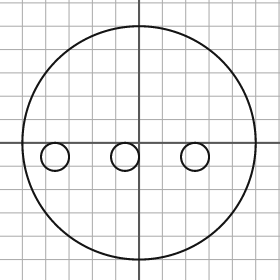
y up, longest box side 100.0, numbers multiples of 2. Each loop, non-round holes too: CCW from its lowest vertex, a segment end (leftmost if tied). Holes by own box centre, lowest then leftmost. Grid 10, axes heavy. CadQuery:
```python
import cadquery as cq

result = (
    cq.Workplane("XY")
    .moveTo(0.0, 0.0)
    .circle(50.0)
    .moveTo(-36.0, -6.0)
    .circle(6.0)
    .moveTo(-6.0, -6.0)
    .circle(6.0)
    .moveTo(24.0, -6.0)
    .circle(6.0)
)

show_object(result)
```